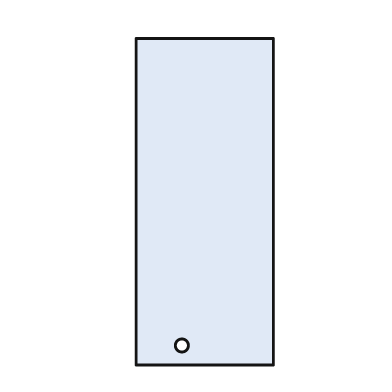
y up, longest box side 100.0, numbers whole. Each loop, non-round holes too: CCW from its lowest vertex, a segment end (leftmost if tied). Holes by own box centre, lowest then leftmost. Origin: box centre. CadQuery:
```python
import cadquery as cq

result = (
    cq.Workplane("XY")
    .moveTo(-21.0, -50.0)
    .lineTo(21.0, -50.0)
    .lineTo(21.0, 50.0)
    .lineTo(-21.0, 50.0)
    .close()
    .moveTo(-7.0, -44.0)
    .circle(2.0)
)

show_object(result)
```